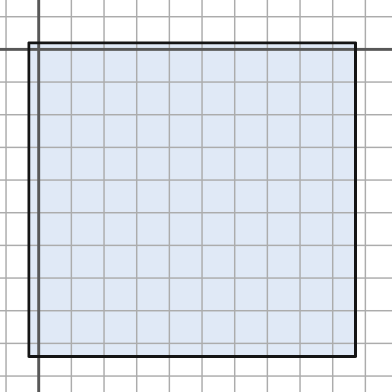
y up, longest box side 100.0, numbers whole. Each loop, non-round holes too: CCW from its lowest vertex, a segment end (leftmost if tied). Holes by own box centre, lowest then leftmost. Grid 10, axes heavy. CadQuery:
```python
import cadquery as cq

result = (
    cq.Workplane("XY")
    .moveTo(-3.0, -94.0)
    .lineTo(97.0, -94.0)
    .lineTo(97.0, 2.0)
    .lineTo(-3.0, 2.0)
    .close()
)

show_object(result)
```